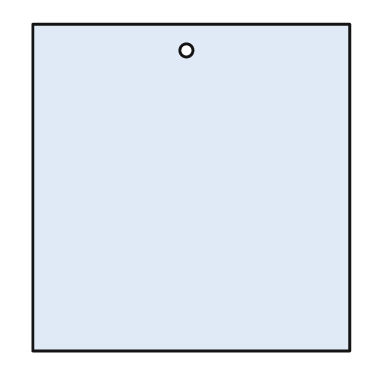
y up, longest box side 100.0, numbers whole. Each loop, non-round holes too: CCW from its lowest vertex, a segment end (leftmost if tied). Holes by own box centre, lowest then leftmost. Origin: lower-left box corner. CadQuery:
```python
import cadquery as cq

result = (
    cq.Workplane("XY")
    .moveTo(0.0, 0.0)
    .lineTo(97.0, 0.0)
    .lineTo(97.0, 100.0)
    .lineTo(0.0, 100.0)
    .close()
    .moveTo(47.0, 92.0)
    .circle(2.0)
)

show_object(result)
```